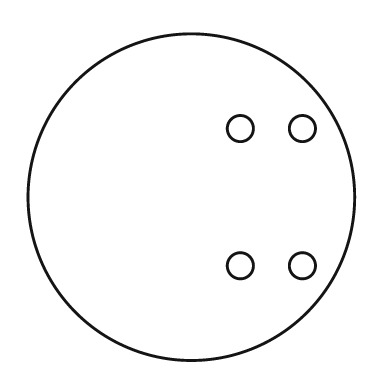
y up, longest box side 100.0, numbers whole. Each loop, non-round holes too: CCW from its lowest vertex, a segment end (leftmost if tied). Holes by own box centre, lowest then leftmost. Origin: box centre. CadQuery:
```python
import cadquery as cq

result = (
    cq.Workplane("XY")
    .moveTo(0.0, 0.0)
    .circle(50.0)
    .moveTo(15.0, -21.0)
    .circle(4.0)
    .moveTo(34.0, -21.0)
    .circle(4.0)
    .moveTo(15.0, 21.0)
    .circle(4.0)
    .moveTo(34.0, 21.0)
    .circle(4.0)
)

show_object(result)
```